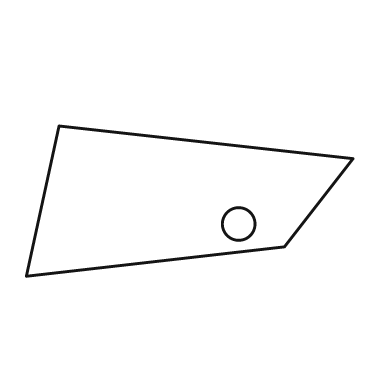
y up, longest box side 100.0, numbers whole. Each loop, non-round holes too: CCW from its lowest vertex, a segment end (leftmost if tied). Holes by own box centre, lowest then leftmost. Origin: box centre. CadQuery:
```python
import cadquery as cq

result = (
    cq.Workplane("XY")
    .moveTo(-50.0, -23.0)
    .lineTo(29.0, -14.0)
    .lineTo(50.0, 13.0)
    .lineTo(-40.0, 23.0)
    .close()
    .moveTo(15.0, -7.0)
    .circle(5.0)
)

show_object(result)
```